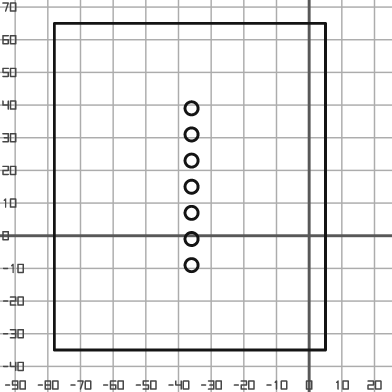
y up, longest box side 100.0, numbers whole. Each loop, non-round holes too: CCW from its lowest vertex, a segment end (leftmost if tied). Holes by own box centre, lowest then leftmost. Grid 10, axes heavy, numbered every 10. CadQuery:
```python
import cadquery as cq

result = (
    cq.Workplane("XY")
    .moveTo(-78.0, -35.0)
    .lineTo(5.0, -35.0)
    .lineTo(5.0, 65.0)
    .lineTo(-78.0, 65.0)
    .close()
    .moveTo(-36.0, -9.0)
    .circle(2.0)
    .moveTo(-36.0, -1.0)
    .circle(2.0)
    .moveTo(-36.0, 7.0)
    .circle(2.0)
    .moveTo(-36.0, 15.0)
    .circle(2.0)
    .moveTo(-36.0, 23.0)
    .circle(2.0)
    .moveTo(-36.0, 31.0)
    .circle(2.0)
    .moveTo(-36.0, 39.0)
    .circle(2.0)
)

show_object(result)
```